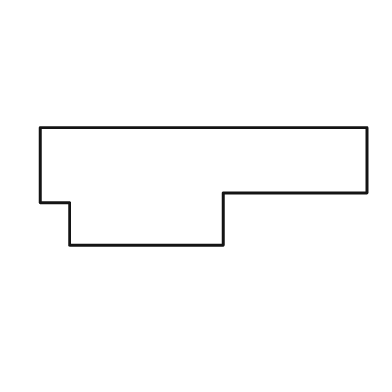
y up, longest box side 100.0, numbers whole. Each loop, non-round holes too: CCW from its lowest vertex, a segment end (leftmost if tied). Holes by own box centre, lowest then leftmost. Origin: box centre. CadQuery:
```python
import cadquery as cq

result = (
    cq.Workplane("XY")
    .moveTo(-41.0, -18.0)
    .lineTo(6.0, -18.0)
    .lineTo(6.0, -2.0)
    .lineTo(50.0, -2.0)
    .lineTo(50.0, 18.0)
    .lineTo(-50.0, 18.0)
    .lineTo(-50.0, -5.0)
    .lineTo(-41.0, -5.0)
    .close()
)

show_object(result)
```